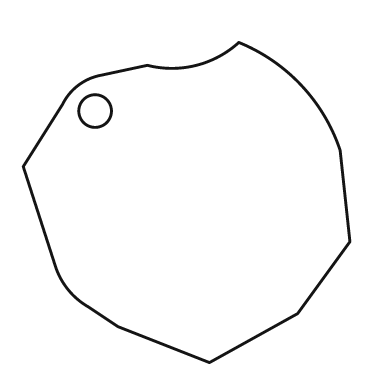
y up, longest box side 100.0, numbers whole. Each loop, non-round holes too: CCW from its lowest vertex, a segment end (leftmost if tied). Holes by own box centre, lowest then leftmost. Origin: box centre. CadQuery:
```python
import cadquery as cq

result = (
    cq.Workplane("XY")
    .moveTo(7.0, -49.0)
    .lineTo(34.0, -34.0)
    .lineTo(50.0, -12.0)
    .lineTo(47.0, 16.0)
    .threePointArc((35.0, 36.0), (16.0, 49.0))
    .threePointArc((3.0, 42.0), (-12.0, 42.0))
    .lineTo(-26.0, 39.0)
    .threePointArc((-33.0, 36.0), (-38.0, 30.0))
    .lineTo(-50.0, 11.0)
    .lineTo(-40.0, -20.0)
    .threePointArc((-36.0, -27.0), (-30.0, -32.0))
    .lineTo(-21.0, -38.0)
    .close()
    .moveTo(-28.0, 28.0)
    .circle(5.0)
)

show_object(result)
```